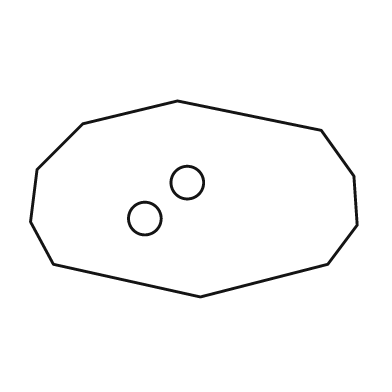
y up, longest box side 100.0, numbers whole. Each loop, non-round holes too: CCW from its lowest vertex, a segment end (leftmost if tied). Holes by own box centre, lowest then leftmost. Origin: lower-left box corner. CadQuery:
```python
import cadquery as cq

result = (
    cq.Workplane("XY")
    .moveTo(52.0, 0.0)
    .lineTo(91.0, 10.0)
    .lineTo(100.0, 22.0)
    .lineTo(99.0, 37.0)
    .lineTo(89.0, 51.0)
    .lineTo(45.0, 60.0)
    .lineTo(16.0, 53.0)
    .lineTo(2.0, 39.0)
    .lineTo(0.0, 23.0)
    .lineTo(7.0, 10.0)
    .close()
    .moveTo(35.0, 24.0)
    .circle(5.0)
    .moveTo(48.0, 35.0)
    .circle(5.0)
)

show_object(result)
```